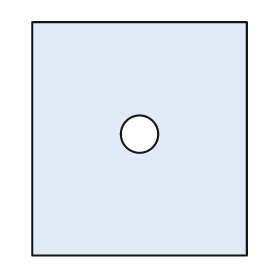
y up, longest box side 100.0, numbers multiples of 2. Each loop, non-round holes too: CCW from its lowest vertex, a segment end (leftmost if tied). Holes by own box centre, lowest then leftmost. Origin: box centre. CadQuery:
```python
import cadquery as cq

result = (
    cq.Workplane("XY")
    .moveTo(-46.0, -50.0)
    .lineTo(46.0, -50.0)
    .lineTo(46.0, 50.0)
    .lineTo(-46.0, 50.0)
    .close()
    .moveTo(0.0, 2.0)
    .circle(8.0)
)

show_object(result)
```